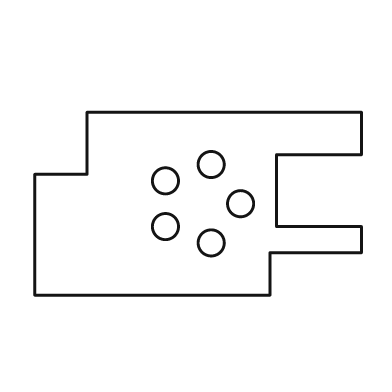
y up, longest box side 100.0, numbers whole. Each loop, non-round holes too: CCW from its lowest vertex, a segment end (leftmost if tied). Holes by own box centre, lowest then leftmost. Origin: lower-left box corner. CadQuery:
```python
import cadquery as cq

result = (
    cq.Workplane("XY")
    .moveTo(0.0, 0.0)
    .lineTo(72.0, 0.0)
    .lineTo(72.0, 13.0)
    .lineTo(100.0, 13.0)
    .lineTo(100.0, 21.0)
    .lineTo(74.0, 21.0)
    .lineTo(74.0, 43.0)
    .lineTo(100.0, 43.0)
    .lineTo(100.0, 56.0)
    .lineTo(16.0, 56.0)
    .lineTo(16.0, 37.0)
    .lineTo(0.0, 37.0)
    .close()
    .moveTo(54.0, 16.0)
    .circle(4.0)
    .moveTo(40.0, 21.0)
    .circle(4.0)
    .moveTo(63.0, 28.0)
    .circle(4.0)
    .moveTo(40.0, 35.0)
    .circle(4.0)
    .moveTo(54.0, 40.0)
    .circle(4.0)
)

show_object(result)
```